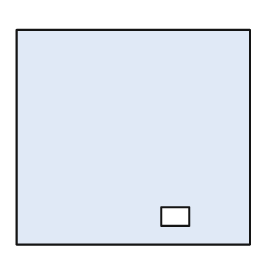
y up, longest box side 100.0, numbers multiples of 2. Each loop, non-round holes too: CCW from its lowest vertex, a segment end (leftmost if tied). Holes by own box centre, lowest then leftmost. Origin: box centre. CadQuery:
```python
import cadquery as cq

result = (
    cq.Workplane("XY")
    .moveTo(-50.0, -46.0)
    .lineTo(50.0, -46.0)
    .lineTo(50.0, 46.0)
    .lineTo(-50.0, 46.0)
    .close()
    .moveTo(12.0, -38.0)
    .lineTo(24.0, -38.0)
    .lineTo(24.0, -30.0)
    .lineTo(12.0, -30.0)
    .close()
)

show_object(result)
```